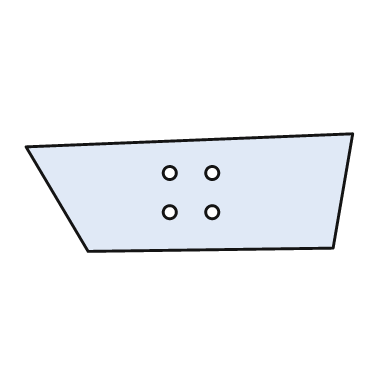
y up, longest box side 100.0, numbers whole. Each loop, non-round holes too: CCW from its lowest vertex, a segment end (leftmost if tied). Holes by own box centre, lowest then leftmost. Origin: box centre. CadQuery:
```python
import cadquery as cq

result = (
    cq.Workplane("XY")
    .moveTo(-31.0, -18.0)
    .lineTo(44.0, -17.0)
    .lineTo(50.0, 18.0)
    .lineTo(-50.0, 14.0)
    .close()
    .moveTo(-6.0, -6.0)
    .circle(2.0)
    .moveTo(7.0, -6.0)
    .circle(2.0)
    .moveTo(-6.0, 6.0)
    .circle(2.0)
    .moveTo(7.0, 6.0)
    .circle(2.0)
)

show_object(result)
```